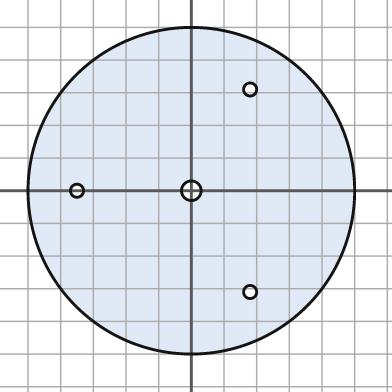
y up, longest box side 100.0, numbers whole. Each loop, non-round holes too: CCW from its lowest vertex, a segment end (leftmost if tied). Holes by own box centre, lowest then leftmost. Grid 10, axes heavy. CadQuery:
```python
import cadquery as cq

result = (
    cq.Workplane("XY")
    .moveTo(0.0, 0.0)
    .circle(50.0)
    .moveTo(18.0, -31.0)
    .circle(2.0)
    .moveTo(-35.0, 0.0)
    .circle(2.0)
    .moveTo(0.0, 0.0)
    .circle(3.0)
    .moveTo(18.0, 31.0)
    .circle(2.0)
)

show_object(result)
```